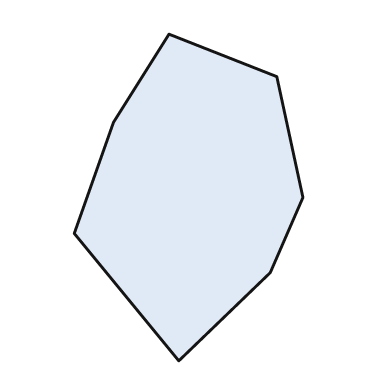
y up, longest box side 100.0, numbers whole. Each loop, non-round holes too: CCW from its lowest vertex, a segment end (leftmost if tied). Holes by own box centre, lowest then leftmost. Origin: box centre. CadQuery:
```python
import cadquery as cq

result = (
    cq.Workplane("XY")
    .moveTo(-3.0, -50.0)
    .lineTo(25.0, -23.0)
    .lineTo(35.0, 0.0)
    .lineTo(27.0, 37.0)
    .lineTo(-6.0, 50.0)
    .lineTo(-23.0, 23.0)
    .lineTo(-35.0, -11.0)
    .close()
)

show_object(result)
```